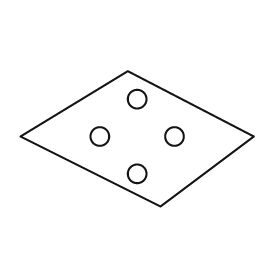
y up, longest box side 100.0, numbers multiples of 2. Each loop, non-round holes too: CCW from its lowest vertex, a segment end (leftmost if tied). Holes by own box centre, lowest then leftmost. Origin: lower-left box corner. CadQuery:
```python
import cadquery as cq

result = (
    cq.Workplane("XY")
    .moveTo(60.0, 0.0)
    .lineTo(100.0, 30.0)
    .lineTo(46.0, 58.0)
    .lineTo(0.0, 30.0)
    .close()
    .moveTo(50.0, 14.0)
    .circle(4.0)
    .moveTo(34.0, 30.0)
    .circle(4.0)
    .moveTo(66.0, 30.0)
    .circle(4.0)
    .moveTo(50.0, 46.0)
    .circle(4.0)
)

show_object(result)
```